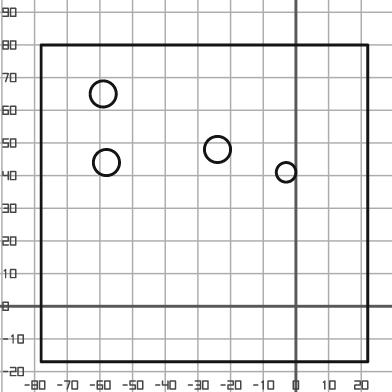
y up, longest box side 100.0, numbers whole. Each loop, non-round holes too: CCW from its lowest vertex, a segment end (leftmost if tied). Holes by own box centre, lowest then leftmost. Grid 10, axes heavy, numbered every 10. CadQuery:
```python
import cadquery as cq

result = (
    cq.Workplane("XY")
    .moveTo(-78.0, -17.0)
    .lineTo(22.0, -17.0)
    .lineTo(22.0, 80.0)
    .lineTo(-78.0, 80.0)
    .close()
    .moveTo(-3.0, 41.0)
    .circle(3.0)
    .moveTo(-58.0, 44.0)
    .circle(4.0)
    .moveTo(-24.0, 48.0)
    .circle(4.0)
    .moveTo(-59.0, 65.0)
    .circle(4.0)
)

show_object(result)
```